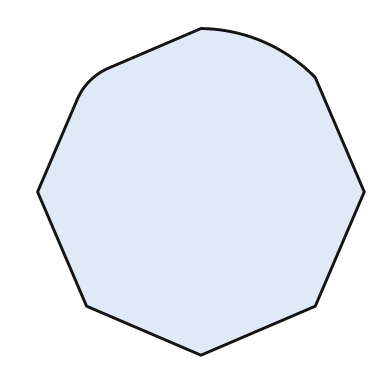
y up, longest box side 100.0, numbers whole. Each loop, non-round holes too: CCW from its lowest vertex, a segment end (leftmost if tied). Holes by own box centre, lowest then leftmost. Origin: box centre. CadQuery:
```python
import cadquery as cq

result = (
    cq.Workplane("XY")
    .moveTo(0.0, -50.0)
    .lineTo(35.0, -35.0)
    .lineTo(50.0, 0.0)
    .lineTo(35.0, 35.0)
    .threePointArc((19.0, 46.0), (0.0, 50.0))
    .lineTo(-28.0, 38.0)
    .threePointArc((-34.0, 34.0), (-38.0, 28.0))
    .lineTo(-50.0, 0.0)
    .lineTo(-35.0, -35.0)
    .close()
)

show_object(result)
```